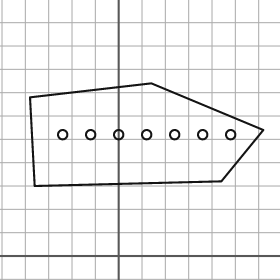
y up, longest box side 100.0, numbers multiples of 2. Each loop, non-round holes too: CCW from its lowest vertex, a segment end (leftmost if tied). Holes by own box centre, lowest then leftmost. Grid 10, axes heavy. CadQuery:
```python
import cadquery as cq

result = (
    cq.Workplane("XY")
    .moveTo(-36.0, 30.0)
    .lineTo(44.0, 32.0)
    .lineTo(62.0, 54.0)
    .lineTo(14.0, 74.0)
    .lineTo(-38.0, 68.0)
    .close()
    .moveTo(-24.0, 52.0)
    .circle(2.0)
    .moveTo(-12.0, 52.0)
    .circle(2.0)
    .moveTo(0.0, 52.0)
    .circle(2.0)
    .moveTo(12.0, 52.0)
    .circle(2.0)
    .moveTo(24.0, 52.0)
    .circle(2.0)
    .moveTo(36.0, 52.0)
    .circle(2.0)
    .moveTo(48.0, 52.0)
    .circle(2.0)
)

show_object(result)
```